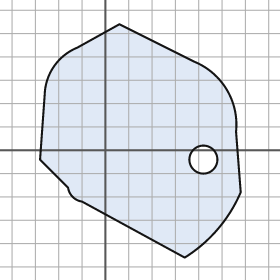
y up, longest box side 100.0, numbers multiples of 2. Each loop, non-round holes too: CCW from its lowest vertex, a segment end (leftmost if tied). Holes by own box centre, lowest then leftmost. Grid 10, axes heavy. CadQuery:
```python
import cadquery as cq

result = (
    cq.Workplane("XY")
    .moveTo(34.0, -46.0)
    .threePointArc((48.0, -34.0), (58.0, -18.0))
    .lineTo(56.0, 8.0)
    .threePointArc((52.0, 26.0), (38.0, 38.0))
    .lineTo(6.0, 54.0)
    .lineTo(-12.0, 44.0)
    .threePointArc((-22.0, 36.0), (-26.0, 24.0))
    .lineTo(-28.0, -4.0)
    .lineTo(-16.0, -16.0)
    .threePointArc((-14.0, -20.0), (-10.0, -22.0))
    .close()
    .moveTo(42.0, -4.0)
    .circle(6.0)
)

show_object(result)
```